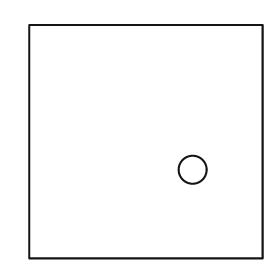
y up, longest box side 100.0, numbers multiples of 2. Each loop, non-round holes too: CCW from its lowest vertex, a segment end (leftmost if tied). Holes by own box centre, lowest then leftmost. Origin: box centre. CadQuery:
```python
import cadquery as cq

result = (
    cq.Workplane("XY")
    .moveTo(-50.0, -50.0)
    .lineTo(50.0, -50.0)
    .lineTo(50.0, 50.0)
    .lineTo(-50.0, 50.0)
    .close()
    .moveTo(20.0, -12.0)
    .circle(6.0)
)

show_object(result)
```